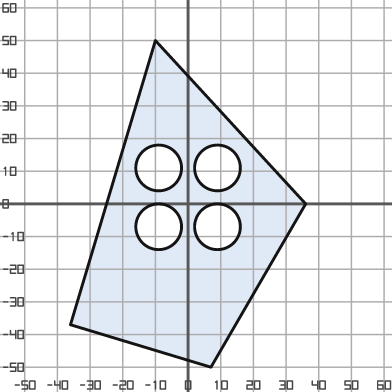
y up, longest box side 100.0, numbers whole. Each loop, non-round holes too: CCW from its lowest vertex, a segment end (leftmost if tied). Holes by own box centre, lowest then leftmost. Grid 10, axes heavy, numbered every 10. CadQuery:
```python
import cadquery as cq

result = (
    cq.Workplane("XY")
    .moveTo(7.0, -50.0)
    .lineTo(36.0, 0.0)
    .lineTo(-10.0, 50.0)
    .lineTo(-36.0, -37.0)
    .close()
    .moveTo(-9.0, -7.0)
    .circle(7.0)
    .moveTo(9.0, -7.0)
    .circle(7.0)
    .moveTo(-9.0, 11.0)
    .circle(7.0)
    .moveTo(9.0, 11.0)
    .circle(7.0)
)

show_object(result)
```